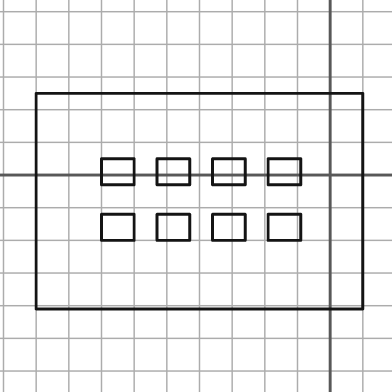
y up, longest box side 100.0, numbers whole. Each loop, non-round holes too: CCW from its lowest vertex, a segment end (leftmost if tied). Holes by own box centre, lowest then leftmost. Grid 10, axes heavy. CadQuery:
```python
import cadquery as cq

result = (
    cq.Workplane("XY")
    .moveTo(-90.0, -41.0)
    .lineTo(10.0, -41.0)
    .lineTo(10.0, 25.0)
    .lineTo(-90.0, 25.0)
    .close()
    .moveTo(-70.0, -20.0)
    .lineTo(-60.0, -20.0)
    .lineTo(-60.0, -12.0)
    .lineTo(-70.0, -12.0)
    .close()
    .moveTo(-53.0, -20.0)
    .lineTo(-43.0, -20.0)
    .lineTo(-43.0, -12.0)
    .lineTo(-53.0, -12.0)
    .close()
    .moveTo(-36.0, -20.0)
    .lineTo(-26.0, -20.0)
    .lineTo(-26.0, -12.0)
    .lineTo(-36.0, -12.0)
    .close()
    .moveTo(-19.0, -20.0)
    .lineTo(-9.0, -20.0)
    .lineTo(-9.0, -12.0)
    .lineTo(-19.0, -12.0)
    .close()
    .moveTo(-70.0, -3.0)
    .lineTo(-60.0, -3.0)
    .lineTo(-60.0, 5.0)
    .lineTo(-70.0, 5.0)
    .close()
    .moveTo(-53.0, -3.0)
    .lineTo(-43.0, -3.0)
    .lineTo(-43.0, 5.0)
    .lineTo(-53.0, 5.0)
    .close()
    .moveTo(-36.0, -3.0)
    .lineTo(-26.0, -3.0)
    .lineTo(-26.0, 5.0)
    .lineTo(-36.0, 5.0)
    .close()
    .moveTo(-19.0, -3.0)
    .lineTo(-9.0, -3.0)
    .lineTo(-9.0, 5.0)
    .lineTo(-19.0, 5.0)
    .close()
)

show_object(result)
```